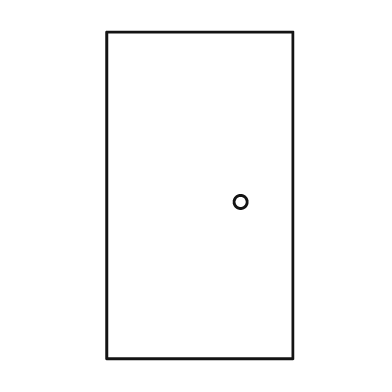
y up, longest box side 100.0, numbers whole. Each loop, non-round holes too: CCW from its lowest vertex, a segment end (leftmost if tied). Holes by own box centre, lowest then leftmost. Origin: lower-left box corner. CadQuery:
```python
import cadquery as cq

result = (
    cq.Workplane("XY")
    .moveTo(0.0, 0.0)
    .lineTo(57.0, 0.0)
    .lineTo(57.0, 100.0)
    .lineTo(0.0, 100.0)
    .close()
    .moveTo(41.0, 48.0)
    .circle(2.0)
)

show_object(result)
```